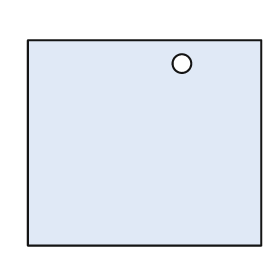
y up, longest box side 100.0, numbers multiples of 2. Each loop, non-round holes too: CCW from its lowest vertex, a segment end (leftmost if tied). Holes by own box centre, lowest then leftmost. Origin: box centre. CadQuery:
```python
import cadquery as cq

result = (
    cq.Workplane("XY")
    .moveTo(-50.0, -44.0)
    .lineTo(50.0, -44.0)
    .lineTo(50.0, 44.0)
    .lineTo(-50.0, 44.0)
    .close()
    .moveTo(16.0, 34.0)
    .circle(4.0)
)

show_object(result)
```